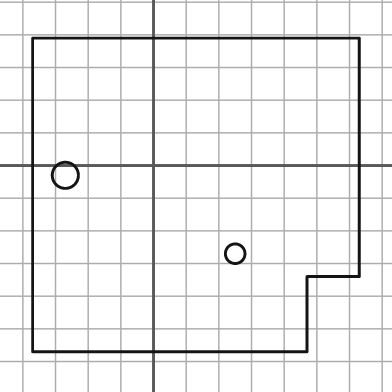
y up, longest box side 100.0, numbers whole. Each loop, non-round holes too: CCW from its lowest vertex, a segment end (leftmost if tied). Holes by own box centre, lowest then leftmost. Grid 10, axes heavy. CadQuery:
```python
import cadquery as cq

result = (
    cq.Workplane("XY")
    .moveTo(-37.0, -57.0)
    .lineTo(47.0, -57.0)
    .lineTo(47.0, -34.0)
    .lineTo(63.0, -34.0)
    .lineTo(63.0, 39.0)
    .lineTo(-37.0, 39.0)
    .close()
    .moveTo(25.0, -27.0)
    .circle(3.0)
    .moveTo(-27.0, -3.0)
    .circle(4.0)
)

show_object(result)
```